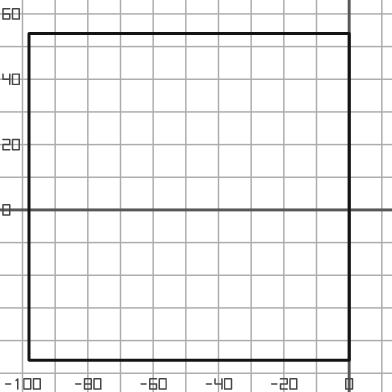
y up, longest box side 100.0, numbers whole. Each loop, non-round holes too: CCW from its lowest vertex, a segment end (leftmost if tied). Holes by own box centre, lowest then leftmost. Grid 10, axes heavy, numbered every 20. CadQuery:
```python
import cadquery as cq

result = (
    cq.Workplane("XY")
    .moveTo(-98.0, -46.0)
    .lineTo(0.0, -46.0)
    .lineTo(0.0, 54.0)
    .lineTo(-98.0, 54.0)
    .close()
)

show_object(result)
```